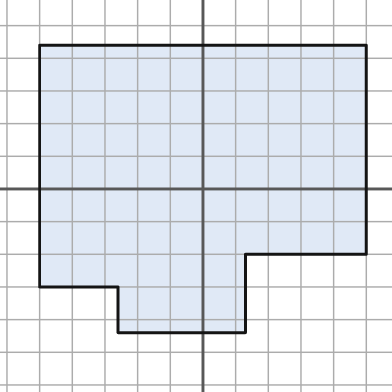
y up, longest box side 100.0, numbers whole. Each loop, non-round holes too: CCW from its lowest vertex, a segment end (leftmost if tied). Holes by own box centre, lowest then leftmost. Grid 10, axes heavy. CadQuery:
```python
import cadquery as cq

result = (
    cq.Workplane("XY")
    .moveTo(-26.0, -44.0)
    .lineTo(13.0, -44.0)
    .lineTo(13.0, -20.0)
    .lineTo(50.0, -20.0)
    .lineTo(50.0, 44.0)
    .lineTo(-50.0, 44.0)
    .lineTo(-50.0, -30.0)
    .lineTo(-26.0, -30.0)
    .close()
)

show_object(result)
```